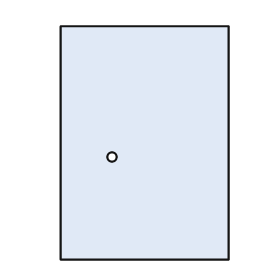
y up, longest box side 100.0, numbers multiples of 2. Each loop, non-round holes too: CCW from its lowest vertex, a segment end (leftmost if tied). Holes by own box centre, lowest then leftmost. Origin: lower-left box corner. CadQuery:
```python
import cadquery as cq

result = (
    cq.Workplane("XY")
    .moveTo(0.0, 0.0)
    .lineTo(72.0, 0.0)
    .lineTo(72.0, 100.0)
    .lineTo(0.0, 100.0)
    .close()
    .moveTo(22.0, 44.0)
    .circle(2.0)
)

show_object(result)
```